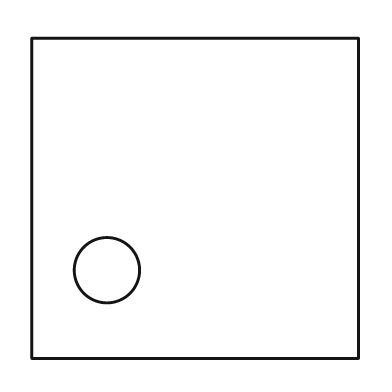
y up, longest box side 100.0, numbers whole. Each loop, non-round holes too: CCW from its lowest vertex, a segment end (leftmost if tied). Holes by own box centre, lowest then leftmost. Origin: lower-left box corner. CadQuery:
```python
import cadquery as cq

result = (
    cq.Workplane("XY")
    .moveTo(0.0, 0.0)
    .lineTo(100.0, 0.0)
    .lineTo(100.0, 98.0)
    .lineTo(0.0, 98.0)
    .close()
    .moveTo(23.0, 27.0)
    .circle(10.0)
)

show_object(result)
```